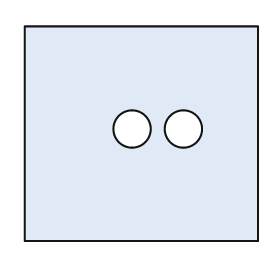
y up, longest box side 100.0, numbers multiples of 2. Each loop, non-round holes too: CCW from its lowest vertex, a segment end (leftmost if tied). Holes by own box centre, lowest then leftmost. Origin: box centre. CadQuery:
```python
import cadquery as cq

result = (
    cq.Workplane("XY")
    .moveTo(-50.0, -46.0)
    .lineTo(50.0, -46.0)
    .lineTo(50.0, 46.0)
    .lineTo(-50.0, 46.0)
    .close()
    .moveTo(-4.0, 2.0)
    .circle(8.0)
    .moveTo(18.0, 2.0)
    .circle(8.0)
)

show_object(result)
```